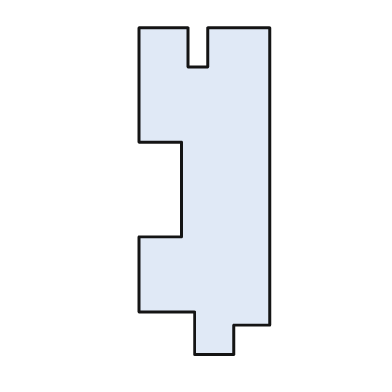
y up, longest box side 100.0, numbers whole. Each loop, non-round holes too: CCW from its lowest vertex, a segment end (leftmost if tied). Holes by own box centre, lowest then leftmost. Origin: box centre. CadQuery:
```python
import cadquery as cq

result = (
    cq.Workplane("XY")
    .moveTo(-3.0, -50.0)
    .lineTo(9.0, -50.0)
    .lineTo(9.0, -41.0)
    .lineTo(20.0, -41.0)
    .lineTo(20.0, 50.0)
    .lineTo(1.0, 50.0)
    .lineTo(1.0, 38.0)
    .lineTo(-5.0, 38.0)
    .lineTo(-5.0, 50.0)
    .lineTo(-20.0, 50.0)
    .lineTo(-20.0, 15.0)
    .lineTo(-7.0, 15.0)
    .lineTo(-7.0, -14.0)
    .lineTo(-20.0, -14.0)
    .lineTo(-20.0, -37.0)
    .lineTo(-3.0, -37.0)
    .close()
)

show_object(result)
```